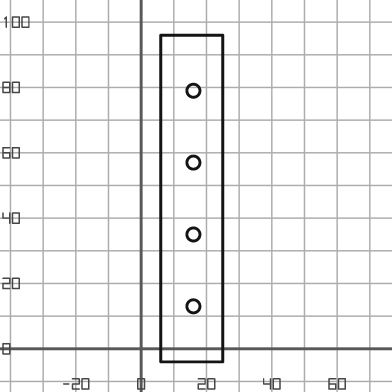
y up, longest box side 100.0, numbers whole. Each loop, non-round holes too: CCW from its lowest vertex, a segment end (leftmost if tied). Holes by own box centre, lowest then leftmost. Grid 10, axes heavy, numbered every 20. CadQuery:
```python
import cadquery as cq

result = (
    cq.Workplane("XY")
    .moveTo(6.0, -4.0)
    .lineTo(25.0, -4.0)
    .lineTo(25.0, 96.0)
    .lineTo(6.0, 96.0)
    .close()
    .moveTo(16.0, 13.0)
    .circle(2.0)
    .moveTo(16.0, 35.0)
    .circle(2.0)
    .moveTo(16.0, 57.0)
    .circle(2.0)
    .moveTo(16.0, 79.0)
    .circle(2.0)
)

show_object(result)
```